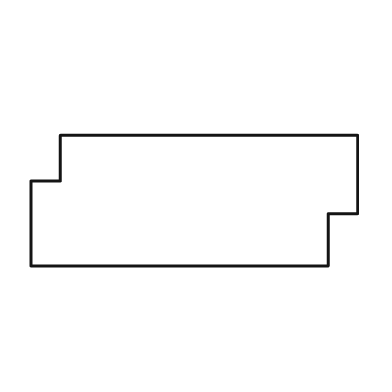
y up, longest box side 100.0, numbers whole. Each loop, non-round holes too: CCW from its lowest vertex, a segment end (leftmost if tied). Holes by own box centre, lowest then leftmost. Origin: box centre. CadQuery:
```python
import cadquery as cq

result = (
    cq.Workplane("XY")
    .moveTo(-50.0, -20.0)
    .lineTo(41.0, -20.0)
    .lineTo(41.0, -4.0)
    .lineTo(50.0, -4.0)
    .lineTo(50.0, 20.0)
    .lineTo(-41.0, 20.0)
    .lineTo(-41.0, 6.0)
    .lineTo(-50.0, 6.0)
    .close()
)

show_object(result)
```